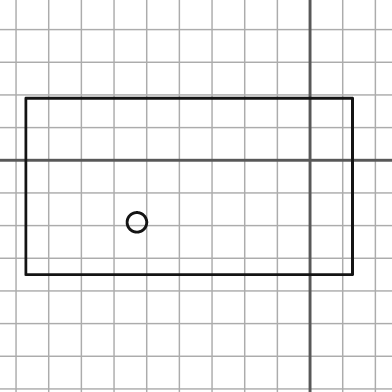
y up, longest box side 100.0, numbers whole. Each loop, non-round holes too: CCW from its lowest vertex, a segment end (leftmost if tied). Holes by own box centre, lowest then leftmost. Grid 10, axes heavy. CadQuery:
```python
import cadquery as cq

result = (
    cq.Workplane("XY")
    .moveTo(-87.0, -35.0)
    .lineTo(13.0, -35.0)
    .lineTo(13.0, 19.0)
    .lineTo(-87.0, 19.0)
    .close()
    .moveTo(-53.0, -19.0)
    .circle(3.0)
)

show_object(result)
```